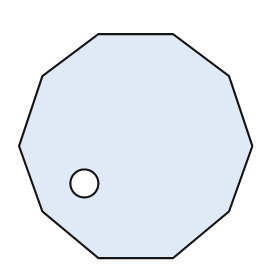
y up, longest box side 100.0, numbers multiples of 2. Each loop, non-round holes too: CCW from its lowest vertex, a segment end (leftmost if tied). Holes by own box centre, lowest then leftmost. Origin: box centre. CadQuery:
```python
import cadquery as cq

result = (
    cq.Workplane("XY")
    .moveTo(-16.0, -48.0)
    .lineTo(16.0, -48.0)
    .lineTo(40.0, -28.0)
    .lineTo(50.0, 0.0)
    .lineTo(40.0, 30.0)
    .lineTo(16.0, 48.0)
    .lineTo(-16.0, 48.0)
    .lineTo(-40.0, 30.0)
    .lineTo(-50.0, 0.0)
    .lineTo(-40.0, -28.0)
    .close()
    .moveTo(-22.0, -16.0)
    .circle(6.0)
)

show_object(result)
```